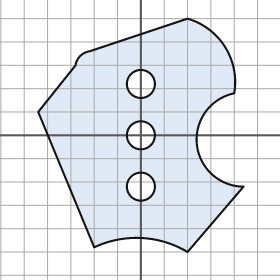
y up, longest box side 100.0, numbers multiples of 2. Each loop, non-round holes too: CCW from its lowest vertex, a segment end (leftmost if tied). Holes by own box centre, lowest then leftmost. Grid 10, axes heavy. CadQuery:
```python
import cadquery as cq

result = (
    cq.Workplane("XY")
    .moveTo(20.0, -50.0)
    .lineTo(44.0, -22.0)
    .threePointArc((24.0, -4.0), (40.0, 18.0))
    .threePointArc((36.0, 38.0), (20.0, 50.0))
    .lineTo(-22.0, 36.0)
    .threePointArc((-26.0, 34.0), (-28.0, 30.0))
    .lineTo(-44.0, 10.0)
    .lineTo(-20.0, -48.0)
    .threePointArc((0.0, -44.0), (20.0, -50.0))
    .close()
    .moveTo(0.0, -22.0)
    .circle(6.0)
    .moveTo(0.0, 0.0)
    .circle(6.0)
    .moveTo(0.0, 22.0)
    .circle(6.0)
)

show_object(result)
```